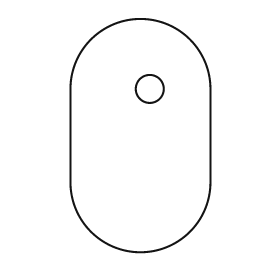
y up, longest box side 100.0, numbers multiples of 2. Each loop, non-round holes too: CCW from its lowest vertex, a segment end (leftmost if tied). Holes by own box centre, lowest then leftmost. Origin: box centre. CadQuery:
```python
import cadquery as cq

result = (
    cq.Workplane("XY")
    .moveTo(-30.0, -20.0)
    .threePointArc((0.0, -50.0), (30.0, -20.0))
    .lineTo(30.0, 20.0)
    .threePointArc((0.0, 50.0), (-30.0, 20.0))
    .close()
    .moveTo(4.0, 20.0)
    .circle(6.0)
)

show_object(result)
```